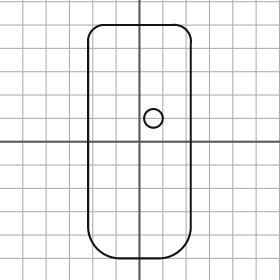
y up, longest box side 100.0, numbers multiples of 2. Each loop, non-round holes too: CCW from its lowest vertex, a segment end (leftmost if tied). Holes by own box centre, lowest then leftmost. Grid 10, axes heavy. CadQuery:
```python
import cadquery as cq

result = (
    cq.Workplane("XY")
    .moveTo(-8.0, -50.0)
    .lineTo(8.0, -50.0)
    .threePointArc((18.0, -46.0), (22.0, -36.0))
    .lineTo(22.0, 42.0)
    .threePointArc((20.0, 48.0), (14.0, 50.0))
    .lineTo(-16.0, 50.0)
    .threePointArc((-20.0, 48.0), (-22.0, 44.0))
    .lineTo(-22.0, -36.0)
    .threePointArc((-18.0, -46.0), (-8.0, -50.0))
    .close()
    .moveTo(6.0, 10.0)
    .circle(4.0)
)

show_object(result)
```